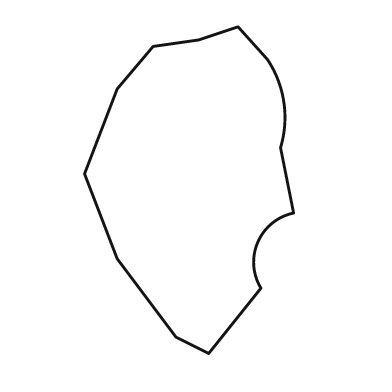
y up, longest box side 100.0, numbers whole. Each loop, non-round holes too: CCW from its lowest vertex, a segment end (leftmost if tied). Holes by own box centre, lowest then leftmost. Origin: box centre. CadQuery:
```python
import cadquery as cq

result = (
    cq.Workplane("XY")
    .moveTo(6.0, -50.0)
    .lineTo(22.0, -30.0)
    .threePointArc((21.0, -16.0), (32.0, -7.0))
    .lineTo(28.0, 13.0)
    .threePointArc((29.0, 27.0), (24.0, 40.0))
    .lineTo(15.0, 50.0)
    .lineTo(3.0, 46.0)
    .lineTo(-11.0, 44.0)
    .lineTo(-22.0, 31.0)
    .lineTo(-32.0, 5.0)
    .lineTo(-22.0, -21.0)
    .lineTo(-4.0, -45.0)
    .close()
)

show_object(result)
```